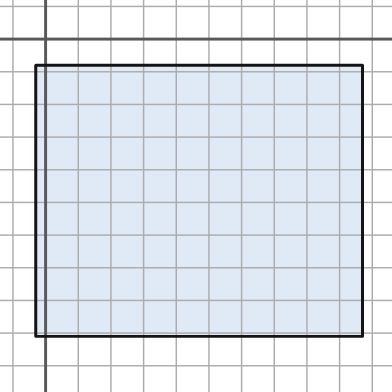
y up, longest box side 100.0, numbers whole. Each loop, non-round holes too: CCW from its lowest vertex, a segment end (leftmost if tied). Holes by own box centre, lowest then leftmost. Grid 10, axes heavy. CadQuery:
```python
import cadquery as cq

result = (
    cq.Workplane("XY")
    .moveTo(-3.0, -91.0)
    .lineTo(97.0, -91.0)
    .lineTo(97.0, -8.0)
    .lineTo(-3.0, -8.0)
    .close()
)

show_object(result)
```